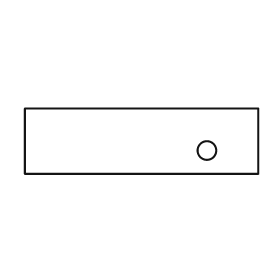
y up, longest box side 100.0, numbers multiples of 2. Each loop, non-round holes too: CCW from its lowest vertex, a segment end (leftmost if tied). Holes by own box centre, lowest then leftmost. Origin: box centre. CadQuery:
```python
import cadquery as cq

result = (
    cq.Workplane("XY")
    .moveTo(-50.0, -14.0)
    .lineTo(50.0, -14.0)
    .lineTo(50.0, 14.0)
    .lineTo(-50.0, 14.0)
    .close()
    .moveTo(28.0, -4.0)
    .circle(4.0)
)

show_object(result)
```